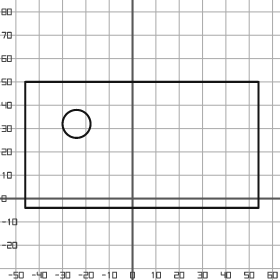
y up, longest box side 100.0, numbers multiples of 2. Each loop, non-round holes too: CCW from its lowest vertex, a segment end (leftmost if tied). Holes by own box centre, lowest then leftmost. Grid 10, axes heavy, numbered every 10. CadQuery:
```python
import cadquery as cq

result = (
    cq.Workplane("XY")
    .moveTo(-46.0, -4.0)
    .lineTo(54.0, -4.0)
    .lineTo(54.0, 50.0)
    .lineTo(-46.0, 50.0)
    .close()
    .moveTo(-24.0, 32.0)
    .circle(6.0)
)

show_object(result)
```